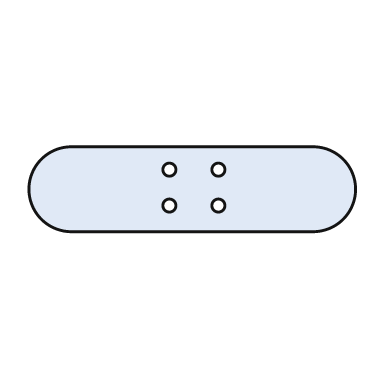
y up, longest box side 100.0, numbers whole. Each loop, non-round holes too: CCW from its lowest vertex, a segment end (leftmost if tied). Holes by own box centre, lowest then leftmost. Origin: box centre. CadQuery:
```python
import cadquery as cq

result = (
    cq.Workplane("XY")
    .moveTo(-37.0, -13.0)
    .lineTo(37.0, -13.0)
    .threePointArc((50.0, 0.0), (37.0, 13.0))
    .lineTo(-37.0, 13.0)
    .threePointArc((-50.0, 0.0), (-37.0, -13.0))
    .close()
    .moveTo(-7.0, -5.0)
    .circle(2.0)
    .moveTo(8.0, -5.0)
    .circle(2.0)
    .moveTo(-7.0, 6.0)
    .circle(2.0)
    .moveTo(8.0, 6.0)
    .circle(2.0)
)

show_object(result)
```